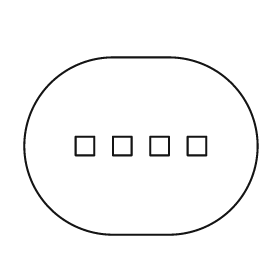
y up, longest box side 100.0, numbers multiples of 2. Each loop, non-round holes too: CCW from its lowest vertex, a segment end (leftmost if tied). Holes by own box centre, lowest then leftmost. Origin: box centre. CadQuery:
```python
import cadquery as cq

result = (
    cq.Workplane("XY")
    .moveTo(-12.0, -38.0)
    .lineTo(12.0, -38.0)
    .threePointArc((50.0, 0.0), (12.0, 38.0))
    .lineTo(-12.0, 38.0)
    .threePointArc((-50.0, 0.0), (-12.0, -38.0))
    .close()
    .moveTo(-28.0, -4.0)
    .lineTo(-20.0, -4.0)
    .lineTo(-20.0, 4.0)
    .lineTo(-28.0, 4.0)
    .close()
    .moveTo(-12.0, -4.0)
    .lineTo(-4.0, -4.0)
    .lineTo(-4.0, 4.0)
    .lineTo(-12.0, 4.0)
    .close()
    .moveTo(4.0, -4.0)
    .lineTo(12.0, -4.0)
    .lineTo(12.0, 4.0)
    .lineTo(4.0, 4.0)
    .close()
    .moveTo(20.0, -4.0)
    .lineTo(28.0, -4.0)
    .lineTo(28.0, 4.0)
    .lineTo(20.0, 4.0)
    .close()
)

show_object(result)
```